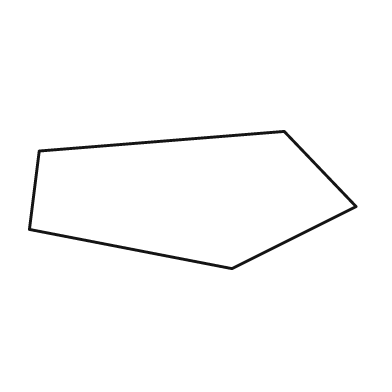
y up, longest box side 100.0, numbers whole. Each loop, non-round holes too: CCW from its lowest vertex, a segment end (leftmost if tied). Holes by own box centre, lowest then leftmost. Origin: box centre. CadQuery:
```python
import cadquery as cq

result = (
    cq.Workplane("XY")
    .moveTo(12.0, -21.0)
    .lineTo(50.0, -2.0)
    .lineTo(28.0, 21.0)
    .lineTo(-47.0, 15.0)
    .lineTo(-50.0, -9.0)
    .close()
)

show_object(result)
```